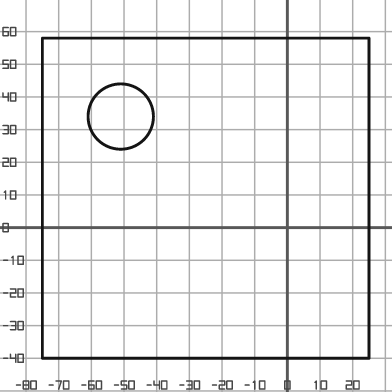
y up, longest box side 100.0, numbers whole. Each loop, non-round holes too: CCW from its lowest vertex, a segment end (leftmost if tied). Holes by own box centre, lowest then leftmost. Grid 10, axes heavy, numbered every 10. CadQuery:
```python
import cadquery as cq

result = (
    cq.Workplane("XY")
    .moveTo(-75.0, -40.0)
    .lineTo(25.0, -40.0)
    .lineTo(25.0, 58.0)
    .lineTo(-75.0, 58.0)
    .close()
    .moveTo(-51.0, 34.0)
    .circle(10.0)
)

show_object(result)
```